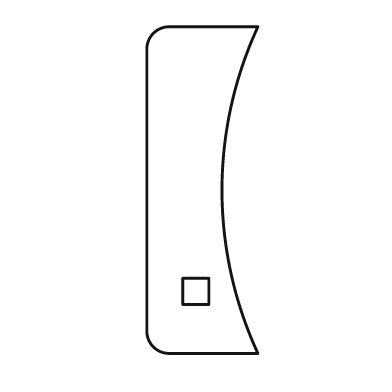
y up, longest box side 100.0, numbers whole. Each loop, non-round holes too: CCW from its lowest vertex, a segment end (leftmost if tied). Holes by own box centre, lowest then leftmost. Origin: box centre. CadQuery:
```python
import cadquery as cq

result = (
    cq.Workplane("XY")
    .moveTo(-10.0, -50.0)
    .lineTo(17.0, -50.0)
    .threePointArc((6.0, 0.0), (17.0, 50.0))
    .lineTo(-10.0, 50.0)
    .threePointArc((-15.0, 48.0), (-17.0, 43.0))
    .lineTo(-17.0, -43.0)
    .threePointArc((-15.0, -48.0), (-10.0, -50.0))
    .close()
    .moveTo(-6.0, -35.0)
    .lineTo(2.0, -35.0)
    .lineTo(2.0, -27.0)
    .lineTo(-6.0, -27.0)
    .close()
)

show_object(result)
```